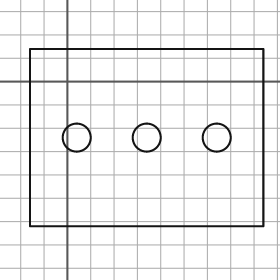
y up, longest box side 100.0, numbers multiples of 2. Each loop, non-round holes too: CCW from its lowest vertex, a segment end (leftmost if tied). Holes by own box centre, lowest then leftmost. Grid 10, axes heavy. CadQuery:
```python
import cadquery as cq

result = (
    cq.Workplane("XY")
    .moveTo(-16.0, -62.0)
    .lineTo(84.0, -62.0)
    .lineTo(84.0, 14.0)
    .lineTo(-16.0, 14.0)
    .close()
    .moveTo(4.0, -24.0)
    .circle(6.0)
    .moveTo(34.0, -24.0)
    .circle(6.0)
    .moveTo(64.0, -24.0)
    .circle(6.0)
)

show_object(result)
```